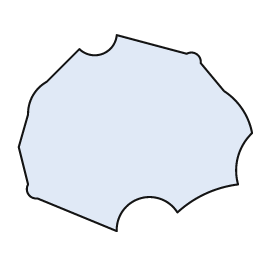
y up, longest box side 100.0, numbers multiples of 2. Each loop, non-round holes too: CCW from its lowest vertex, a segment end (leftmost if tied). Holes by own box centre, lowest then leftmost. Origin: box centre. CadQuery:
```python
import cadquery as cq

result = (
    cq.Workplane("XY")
    .moveTo(-8.0, -42.0)
    .threePointArc((2.0, -28.0), (18.0, -34.0))
    .threePointArc((30.0, -26.0), (44.0, -22.0))
    .threePointArc((44.0, -10.0), (50.0, 0.0))
    .threePointArc((46.0, 10.0), (38.0, 18.0))
    .lineTo(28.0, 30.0)
    .threePointArc((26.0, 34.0), (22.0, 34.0))
    .lineTo(-8.0, 42.0)
    .threePointArc((-14.0, 34.0), (-24.0, 36.0))
    .lineTo(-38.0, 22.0)
    .threePointArc((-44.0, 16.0), (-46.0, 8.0))
    .lineTo(-50.0, -6.0)
    .lineTo(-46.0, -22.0)
    .threePointArc((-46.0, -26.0), (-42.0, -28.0))
    .close()
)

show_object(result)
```